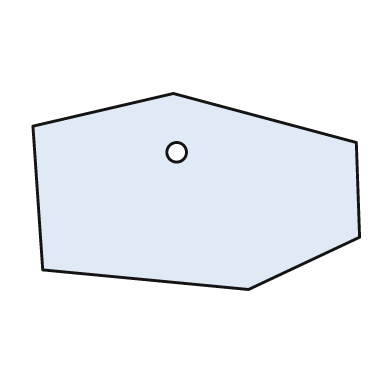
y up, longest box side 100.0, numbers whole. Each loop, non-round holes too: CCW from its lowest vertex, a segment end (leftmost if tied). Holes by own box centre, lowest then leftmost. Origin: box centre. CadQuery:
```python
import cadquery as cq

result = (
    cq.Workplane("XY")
    .moveTo(16.0, -30.0)
    .lineTo(50.0, -14.0)
    .lineTo(49.0, 15.0)
    .lineTo(-7.0, 30.0)
    .lineTo(-50.0, 20.0)
    .lineTo(-47.0, -24.0)
    .close()
    .moveTo(-6.0, 12.0)
    .circle(3.0)
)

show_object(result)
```